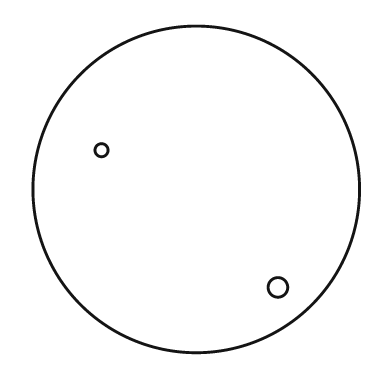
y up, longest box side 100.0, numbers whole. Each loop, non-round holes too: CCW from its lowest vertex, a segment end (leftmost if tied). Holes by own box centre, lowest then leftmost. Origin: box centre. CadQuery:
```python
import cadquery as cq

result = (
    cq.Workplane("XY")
    .moveTo(0.0, 0.0)
    .circle(50.0)
    .moveTo(25.0, -30.0)
    .circle(3.0)
    .moveTo(-29.0, 12.0)
    .circle(2.0)
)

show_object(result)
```